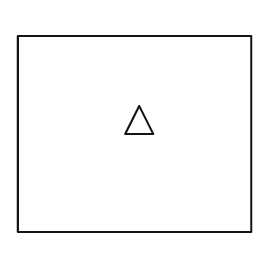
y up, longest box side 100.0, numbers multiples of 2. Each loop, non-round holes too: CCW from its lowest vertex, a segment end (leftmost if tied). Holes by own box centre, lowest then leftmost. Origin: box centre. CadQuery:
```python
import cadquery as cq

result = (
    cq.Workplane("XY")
    .moveTo(-50.0, -42.0)
    .lineTo(50.0, -42.0)
    .lineTo(50.0, 42.0)
    .lineTo(-50.0, 42.0)
    .close()
    .moveTo(-4.0, 0.0)
    .lineTo(8.0, 0.0)
    .lineTo(2.0, 12.0)
    .close()
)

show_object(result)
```